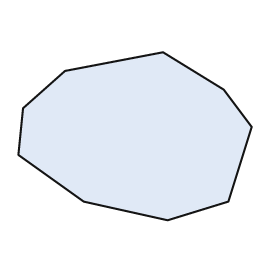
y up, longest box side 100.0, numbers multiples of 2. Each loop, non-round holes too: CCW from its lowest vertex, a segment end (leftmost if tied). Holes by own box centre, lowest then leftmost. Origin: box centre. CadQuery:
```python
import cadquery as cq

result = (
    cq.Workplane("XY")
    .moveTo(14.0, -36.0)
    .lineTo(40.0, -28.0)
    .lineTo(50.0, 4.0)
    .lineTo(38.0, 20.0)
    .lineTo(12.0, 36.0)
    .lineTo(-30.0, 28.0)
    .lineTo(-48.0, 12.0)
    .lineTo(-50.0, -8.0)
    .lineTo(-22.0, -28.0)
    .close()
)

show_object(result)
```